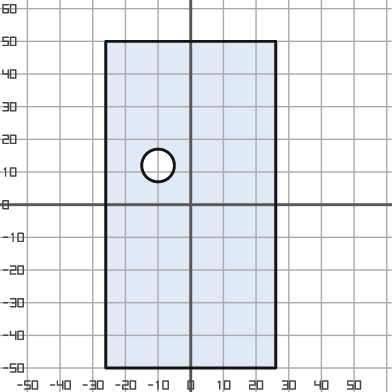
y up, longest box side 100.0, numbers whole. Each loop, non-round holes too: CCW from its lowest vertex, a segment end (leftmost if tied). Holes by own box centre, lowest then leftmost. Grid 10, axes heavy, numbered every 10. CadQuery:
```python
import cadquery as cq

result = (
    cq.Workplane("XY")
    .moveTo(-26.0, -50.0)
    .lineTo(26.0, -50.0)
    .lineTo(26.0, 50.0)
    .lineTo(-26.0, 50.0)
    .close()
    .moveTo(-10.0, 12.0)
    .circle(5.0)
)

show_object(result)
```